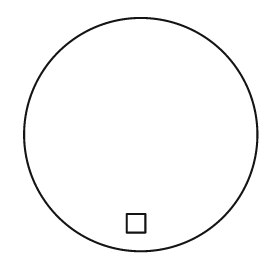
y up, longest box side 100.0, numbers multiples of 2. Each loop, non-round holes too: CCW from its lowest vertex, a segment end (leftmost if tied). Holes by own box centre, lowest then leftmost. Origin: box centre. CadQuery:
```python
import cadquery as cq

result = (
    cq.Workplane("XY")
    .moveTo(0.0, 0.0)
    .circle(50.0)
    .moveTo(-6.0, -42.0)
    .lineTo(2.0, -42.0)
    .lineTo(2.0, -34.0)
    .lineTo(-6.0, -34.0)
    .close()
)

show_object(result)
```